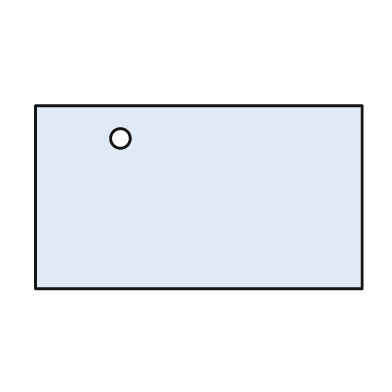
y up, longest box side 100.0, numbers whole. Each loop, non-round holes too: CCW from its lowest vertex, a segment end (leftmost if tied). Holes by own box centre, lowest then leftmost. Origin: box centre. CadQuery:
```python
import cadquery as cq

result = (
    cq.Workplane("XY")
    .moveTo(-50.0, -28.0)
    .lineTo(50.0, -28.0)
    .lineTo(50.0, 28.0)
    .lineTo(-50.0, 28.0)
    .close()
    .moveTo(-24.0, 18.0)
    .circle(3.0)
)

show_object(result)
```